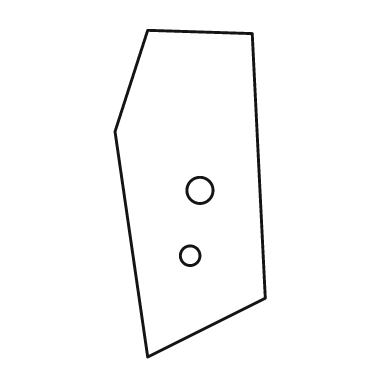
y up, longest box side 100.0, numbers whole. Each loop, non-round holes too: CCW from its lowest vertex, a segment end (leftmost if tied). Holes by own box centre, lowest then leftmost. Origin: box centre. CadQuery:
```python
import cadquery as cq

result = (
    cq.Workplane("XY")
    .moveTo(-13.0, -50.0)
    .lineTo(23.0, -32.0)
    .lineTo(19.0, 49.0)
    .lineTo(-13.0, 50.0)
    .lineTo(-23.0, 19.0)
    .close()
    .moveTo(0.0, -19.0)
    .circle(3.0)
    .moveTo(3.0, 1.0)
    .circle(4.0)
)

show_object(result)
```